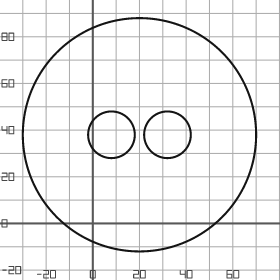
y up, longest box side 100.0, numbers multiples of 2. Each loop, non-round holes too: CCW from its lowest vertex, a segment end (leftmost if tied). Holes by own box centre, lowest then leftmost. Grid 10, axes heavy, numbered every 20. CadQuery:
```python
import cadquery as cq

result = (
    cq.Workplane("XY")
    .moveTo(20.0, 38.0)
    .circle(50.0)
    .moveTo(8.0, 38.0)
    .circle(10.0)
    .moveTo(32.0, 38.0)
    .circle(10.0)
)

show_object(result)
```